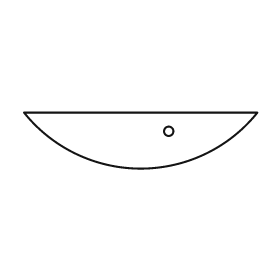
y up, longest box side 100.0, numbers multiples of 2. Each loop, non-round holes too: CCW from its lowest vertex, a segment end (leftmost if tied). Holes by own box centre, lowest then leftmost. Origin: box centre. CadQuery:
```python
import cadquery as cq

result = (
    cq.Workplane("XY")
    .moveTo(-50.0, 12.0)
    .threePointArc((0.0, -12.0), (50.0, 12.0))
    .close()
    .moveTo(12.0, 4.0)
    .circle(2.0)
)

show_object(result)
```